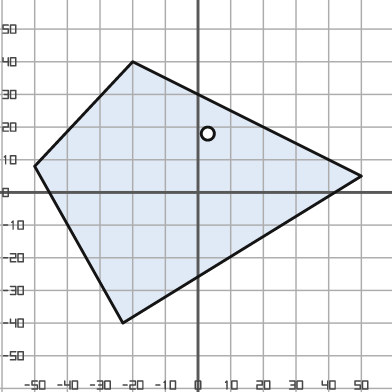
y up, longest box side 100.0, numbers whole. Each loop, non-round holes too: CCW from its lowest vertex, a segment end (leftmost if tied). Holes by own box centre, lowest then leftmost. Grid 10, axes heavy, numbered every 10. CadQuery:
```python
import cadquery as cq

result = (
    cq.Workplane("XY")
    .moveTo(-23.0, -40.0)
    .lineTo(50.0, 5.0)
    .lineTo(-20.0, 40.0)
    .lineTo(-50.0, 8.0)
    .close()
    .moveTo(3.0, 18.0)
    .circle(2.0)
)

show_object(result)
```